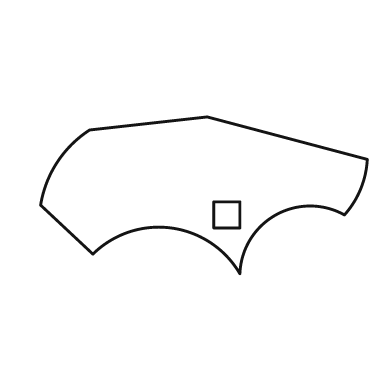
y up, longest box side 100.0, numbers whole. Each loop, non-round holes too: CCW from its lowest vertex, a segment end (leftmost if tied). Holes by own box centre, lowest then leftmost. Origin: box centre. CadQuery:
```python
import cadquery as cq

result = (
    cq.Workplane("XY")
    .moveTo(11.0, -24.0)
    .threePointArc((22.0, -6.0), (43.0, -6.0))
    .threePointArc((48.0, 2.0), (50.0, 11.0))
    .lineTo(1.0, 24.0)
    .lineTo(-35.0, 20.0)
    .threePointArc((-45.0, 10.0), (-50.0, -3.0))
    .lineTo(-34.0, -18.0)
    .threePointArc((-10.0, -10.0), (11.0, -24.0))
    .close()
    .moveTo(3.0, -10.0)
    .lineTo(11.0, -10.0)
    .lineTo(11.0, -2.0)
    .lineTo(3.0, -2.0)
    .close()
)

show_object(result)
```